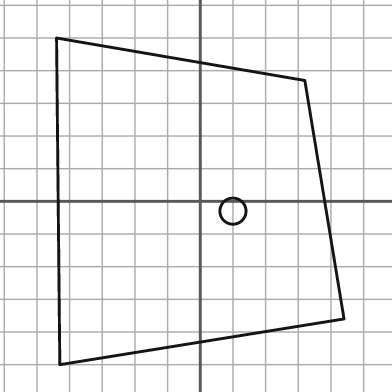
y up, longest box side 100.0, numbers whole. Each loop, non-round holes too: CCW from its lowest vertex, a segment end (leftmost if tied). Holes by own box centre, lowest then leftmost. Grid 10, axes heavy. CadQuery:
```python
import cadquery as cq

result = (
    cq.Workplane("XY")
    .moveTo(-43.0, -50.0)
    .lineTo(44.0, -36.0)
    .lineTo(32.0, 37.0)
    .lineTo(-44.0, 50.0)
    .close()
    .moveTo(10.0, -3.0)
    .circle(4.0)
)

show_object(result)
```